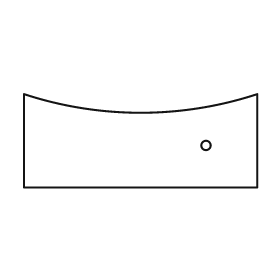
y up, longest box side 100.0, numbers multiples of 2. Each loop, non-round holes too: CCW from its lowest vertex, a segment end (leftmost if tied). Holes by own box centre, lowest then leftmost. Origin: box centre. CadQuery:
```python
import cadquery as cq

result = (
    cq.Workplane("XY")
    .moveTo(-50.0, -20.0)
    .lineTo(50.0, -20.0)
    .lineTo(50.0, 20.0)
    .threePointArc((0.0, 12.0), (-50.0, 20.0))
    .close()
    .moveTo(28.0, -2.0)
    .circle(2.0)
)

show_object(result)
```